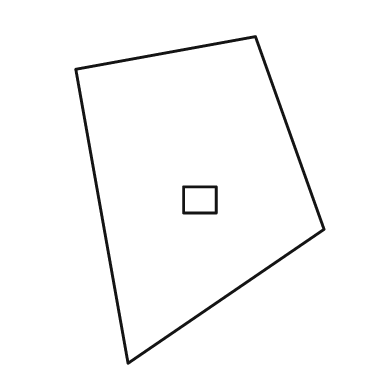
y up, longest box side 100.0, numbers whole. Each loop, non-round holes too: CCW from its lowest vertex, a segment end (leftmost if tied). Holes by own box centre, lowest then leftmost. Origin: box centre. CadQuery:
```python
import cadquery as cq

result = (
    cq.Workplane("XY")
    .moveTo(-22.0, -50.0)
    .lineTo(38.0, -9.0)
    .lineTo(17.0, 50.0)
    .lineTo(-38.0, 40.0)
    .close()
    .moveTo(-5.0, -4.0)
    .lineTo(5.0, -4.0)
    .lineTo(5.0, 4.0)
    .lineTo(-5.0, 4.0)
    .close()
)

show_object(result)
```